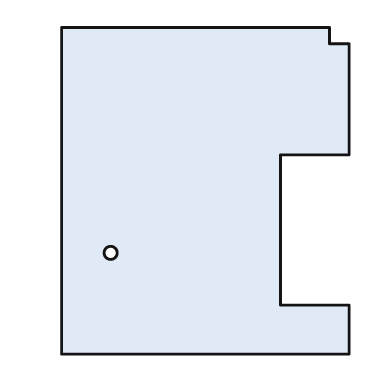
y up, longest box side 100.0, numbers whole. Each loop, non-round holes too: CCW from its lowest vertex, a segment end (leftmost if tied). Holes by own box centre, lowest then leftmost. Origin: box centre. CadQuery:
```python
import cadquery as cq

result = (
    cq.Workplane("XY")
    .moveTo(-44.0, -50.0)
    .lineTo(44.0, -50.0)
    .lineTo(44.0, -35.0)
    .lineTo(23.0, -35.0)
    .lineTo(23.0, 11.0)
    .lineTo(44.0, 11.0)
    .lineTo(44.0, 45.0)
    .lineTo(38.0, 45.0)
    .lineTo(38.0, 50.0)
    .lineTo(-44.0, 50.0)
    .close()
    .moveTo(-29.0, -19.0)
    .circle(2.0)
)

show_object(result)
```